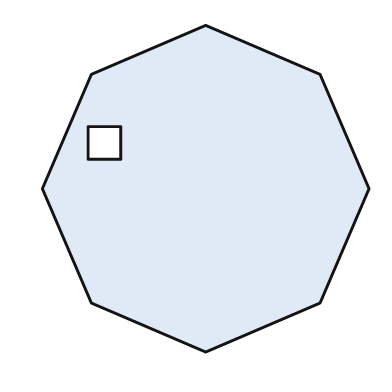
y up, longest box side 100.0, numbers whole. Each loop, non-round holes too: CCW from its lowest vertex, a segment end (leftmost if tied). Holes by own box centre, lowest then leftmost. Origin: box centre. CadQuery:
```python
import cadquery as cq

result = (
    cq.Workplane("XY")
    .moveTo(0.0, -50.0)
    .lineTo(35.0, -35.0)
    .lineTo(50.0, 0.0)
    .lineTo(35.0, 35.0)
    .lineTo(0.0, 50.0)
    .lineTo(-35.0, 35.0)
    .lineTo(-50.0, 0.0)
    .lineTo(-35.0, -35.0)
    .close()
    .moveTo(-36.0, 9.0)
    .lineTo(-26.0, 9.0)
    .lineTo(-26.0, 19.0)
    .lineTo(-36.0, 19.0)
    .close()
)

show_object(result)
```